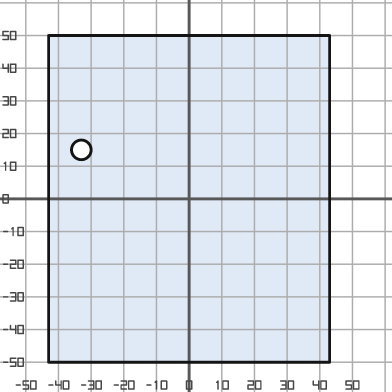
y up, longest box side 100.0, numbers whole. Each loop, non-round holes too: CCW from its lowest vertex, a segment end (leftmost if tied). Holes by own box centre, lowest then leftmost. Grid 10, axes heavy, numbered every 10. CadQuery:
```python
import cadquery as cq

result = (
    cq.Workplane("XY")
    .moveTo(-43.0, -50.0)
    .lineTo(43.0, -50.0)
    .lineTo(43.0, 50.0)
    .lineTo(-43.0, 50.0)
    .close()
    .moveTo(-33.0, 15.0)
    .circle(3.0)
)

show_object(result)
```